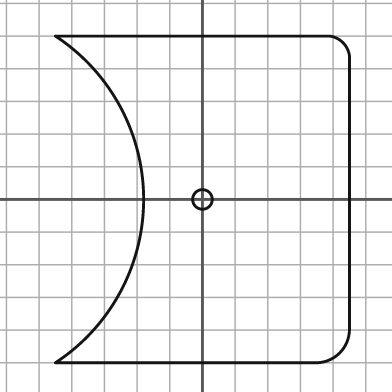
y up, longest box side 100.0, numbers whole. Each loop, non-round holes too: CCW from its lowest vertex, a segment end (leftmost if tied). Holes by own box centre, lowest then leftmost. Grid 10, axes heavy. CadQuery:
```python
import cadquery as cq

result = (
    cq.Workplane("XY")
    .moveTo(-45.0, -50.0)
    .lineTo(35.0, -50.0)
    .threePointArc((42.0, -47.0), (45.0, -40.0))
    .lineTo(45.0, 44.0)
    .threePointArc((43.0, 48.0), (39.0, 50.0))
    .lineTo(-45.0, 50.0)
    .threePointArc((-18.0, 0.0), (-45.0, -50.0))
    .close()
    .moveTo(0.0, 0.0)
    .circle(3.0)
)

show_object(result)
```